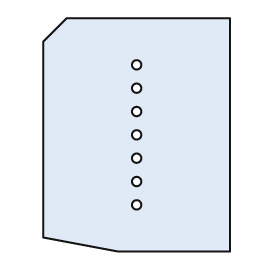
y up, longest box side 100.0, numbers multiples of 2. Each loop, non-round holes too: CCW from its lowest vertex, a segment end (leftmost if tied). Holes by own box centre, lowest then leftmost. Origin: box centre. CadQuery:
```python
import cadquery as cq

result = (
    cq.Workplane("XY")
    .moveTo(-8.0, -50.0)
    .lineTo(40.0, -50.0)
    .lineTo(40.0, 50.0)
    .lineTo(-30.0, 50.0)
    .lineTo(-40.0, 40.0)
    .lineTo(-40.0, -44.0)
    .close()
    .moveTo(0.0, -30.0)
    .circle(2.0)
    .moveTo(0.0, -20.0)
    .circle(2.0)
    .moveTo(0.0, -10.0)
    .circle(2.0)
    .moveTo(0.0, 0.0)
    .circle(2.0)
    .moveTo(0.0, 10.0)
    .circle(2.0)
    .moveTo(0.0, 20.0)
    .circle(2.0)
    .moveTo(0.0, 30.0)
    .circle(2.0)
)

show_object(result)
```